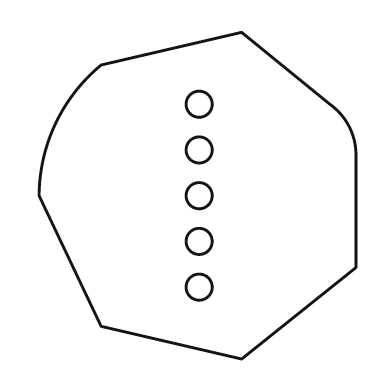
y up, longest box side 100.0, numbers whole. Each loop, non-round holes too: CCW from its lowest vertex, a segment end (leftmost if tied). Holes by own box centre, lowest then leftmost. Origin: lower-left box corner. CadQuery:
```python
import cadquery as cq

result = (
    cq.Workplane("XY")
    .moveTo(62.0, 0.0)
    .lineTo(97.0, 28.0)
    .lineTo(97.0, 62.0)
    .threePointArc((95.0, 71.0), (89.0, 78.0))
    .lineTo(62.0, 100.0)
    .lineTo(19.0, 90.0)
    .threePointArc((5.0, 72.0), (0.0, 50.0))
    .lineTo(19.0, 10.0)
    .close()
    .moveTo(49.0, 22.0)
    .circle(4.0)
    .moveTo(49.0, 36.0)
    .circle(4.0)
    .moveTo(49.0, 50.0)
    .circle(4.0)
    .moveTo(49.0, 64.0)
    .circle(4.0)
    .moveTo(49.0, 78.0)
    .circle(4.0)
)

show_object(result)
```